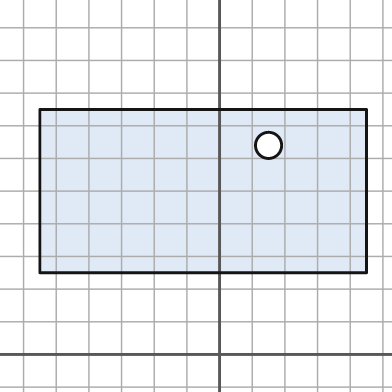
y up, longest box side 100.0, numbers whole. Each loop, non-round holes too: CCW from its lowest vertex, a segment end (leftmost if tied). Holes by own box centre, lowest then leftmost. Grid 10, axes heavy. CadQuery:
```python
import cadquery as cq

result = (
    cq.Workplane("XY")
    .moveTo(-55.0, 25.0)
    .lineTo(45.0, 25.0)
    .lineTo(45.0, 75.0)
    .lineTo(-55.0, 75.0)
    .close()
    .moveTo(15.0, 64.0)
    .circle(4.0)
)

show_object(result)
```